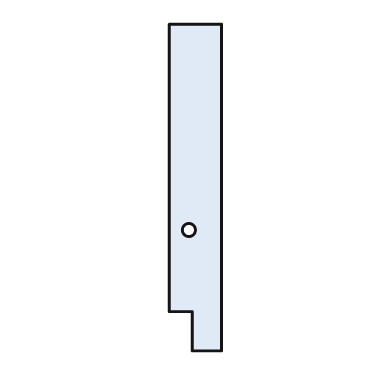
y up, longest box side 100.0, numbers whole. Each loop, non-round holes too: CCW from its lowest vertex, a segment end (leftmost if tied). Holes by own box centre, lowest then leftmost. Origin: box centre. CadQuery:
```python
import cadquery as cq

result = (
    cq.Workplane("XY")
    .moveTo(-1.0, -50.0)
    .lineTo(8.0, -50.0)
    .lineTo(8.0, 50.0)
    .lineTo(-8.0, 50.0)
    .lineTo(-8.0, -38.0)
    .lineTo(-1.0, -38.0)
    .close()
    .moveTo(-2.0, -13.0)
    .circle(2.0)
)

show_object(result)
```